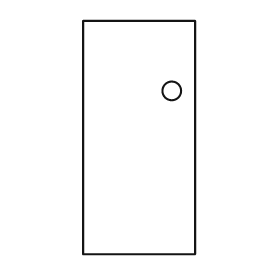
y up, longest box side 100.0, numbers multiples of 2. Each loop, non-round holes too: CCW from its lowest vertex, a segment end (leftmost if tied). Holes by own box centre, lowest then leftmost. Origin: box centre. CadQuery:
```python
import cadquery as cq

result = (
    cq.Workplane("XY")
    .moveTo(-24.0, -50.0)
    .lineTo(24.0, -50.0)
    .lineTo(24.0, 50.0)
    .lineTo(-24.0, 50.0)
    .close()
    .moveTo(14.0, 20.0)
    .circle(4.0)
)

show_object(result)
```